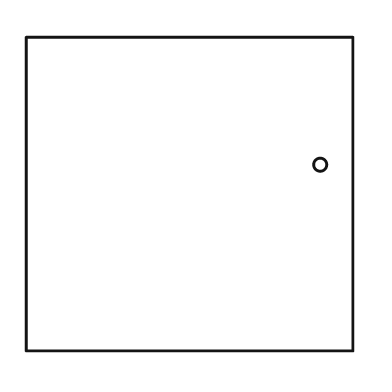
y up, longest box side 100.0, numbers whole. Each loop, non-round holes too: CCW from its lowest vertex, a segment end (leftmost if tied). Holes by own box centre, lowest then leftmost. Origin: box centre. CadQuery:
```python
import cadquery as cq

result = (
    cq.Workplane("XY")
    .moveTo(-50.0, -48.0)
    .lineTo(50.0, -48.0)
    .lineTo(50.0, 48.0)
    .lineTo(-50.0, 48.0)
    .close()
    .moveTo(40.0, 9.0)
    .circle(2.0)
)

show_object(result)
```